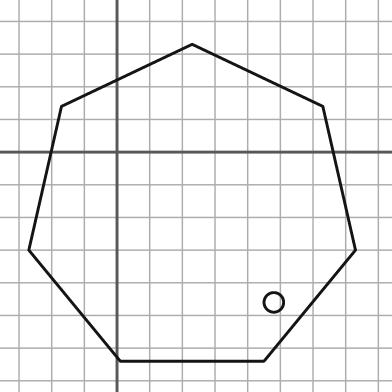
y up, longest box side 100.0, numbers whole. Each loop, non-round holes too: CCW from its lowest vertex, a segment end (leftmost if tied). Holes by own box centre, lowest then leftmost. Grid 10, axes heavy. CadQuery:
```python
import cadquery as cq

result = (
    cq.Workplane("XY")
    .moveTo(1.0, -64.0)
    .lineTo(45.0, -64.0)
    .lineTo(73.0, -30.0)
    .lineTo(63.0, 14.0)
    .lineTo(23.0, 33.0)
    .lineTo(-17.0, 14.0)
    .lineTo(-27.0, -30.0)
    .close()
    .moveTo(48.0, -46.0)
    .circle(3.0)
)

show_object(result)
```